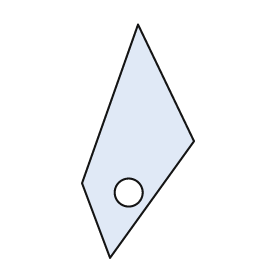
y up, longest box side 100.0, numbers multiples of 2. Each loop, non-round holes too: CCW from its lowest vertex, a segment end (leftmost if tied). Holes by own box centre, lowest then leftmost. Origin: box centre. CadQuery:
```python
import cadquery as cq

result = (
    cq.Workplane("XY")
    .moveTo(-12.0, -50.0)
    .lineTo(24.0, 0.0)
    .lineTo(0.0, 50.0)
    .lineTo(-24.0, -18.0)
    .close()
    .moveTo(-4.0, -22.0)
    .circle(6.0)
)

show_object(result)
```